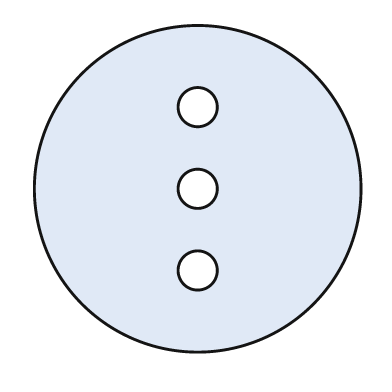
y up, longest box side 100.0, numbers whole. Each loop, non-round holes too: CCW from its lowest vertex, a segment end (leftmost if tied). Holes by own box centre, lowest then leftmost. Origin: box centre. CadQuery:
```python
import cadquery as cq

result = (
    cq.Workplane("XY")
    .moveTo(0.0, 0.0)
    .circle(50.0)
    .moveTo(0.0, -25.0)
    .circle(6.0)
    .moveTo(0.0, 0.0)
    .circle(6.0)
    .moveTo(0.0, 25.0)
    .circle(6.0)
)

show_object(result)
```